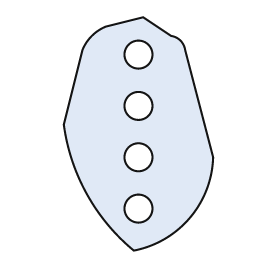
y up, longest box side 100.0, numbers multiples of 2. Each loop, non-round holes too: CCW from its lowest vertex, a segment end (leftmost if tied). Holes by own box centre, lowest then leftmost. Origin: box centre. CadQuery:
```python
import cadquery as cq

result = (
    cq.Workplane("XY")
    .moveTo(-2.0, -50.0)
    .threePointArc((22.0, -36.0), (32.0, -10.0))
    .lineTo(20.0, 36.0)
    .threePointArc((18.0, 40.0), (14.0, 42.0))
    .lineTo(2.0, 50.0)
    .lineTo(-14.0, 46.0)
    .threePointArc((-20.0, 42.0), (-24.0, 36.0))
    .lineTo(-32.0, 4.0)
    .threePointArc((-22.0, -26.0), (-2.0, -50.0))
    .close()
    .moveTo(0.0, -32.0)
    .circle(6.0)
    .moveTo(0.0, -10.0)
    .circle(6.0)
    .moveTo(0.0, 12.0)
    .circle(6.0)
    .moveTo(0.0, 34.0)
    .circle(6.0)
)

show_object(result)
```